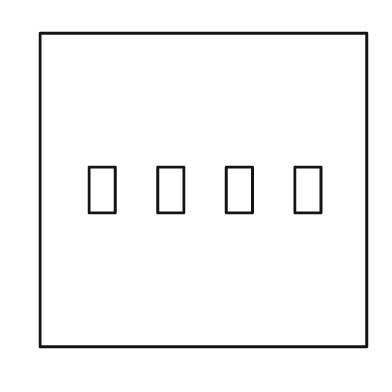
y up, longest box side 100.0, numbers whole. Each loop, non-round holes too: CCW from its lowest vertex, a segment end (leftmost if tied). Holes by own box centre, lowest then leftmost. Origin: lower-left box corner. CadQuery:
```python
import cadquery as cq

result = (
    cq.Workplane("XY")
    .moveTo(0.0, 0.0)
    .lineTo(100.0, 0.0)
    .lineTo(100.0, 96.0)
    .lineTo(0.0, 96.0)
    .close()
    .moveTo(15.0, 41.0)
    .lineTo(23.0, 41.0)
    .lineTo(23.0, 55.0)
    .lineTo(15.0, 55.0)
    .close()
    .moveTo(36.0, 41.0)
    .lineTo(44.0, 41.0)
    .lineTo(44.0, 55.0)
    .lineTo(36.0, 55.0)
    .close()
    .moveTo(57.0, 41.0)
    .lineTo(65.0, 41.0)
    .lineTo(65.0, 55.0)
    .lineTo(57.0, 55.0)
    .close()
    .moveTo(78.0, 41.0)
    .lineTo(86.0, 41.0)
    .lineTo(86.0, 55.0)
    .lineTo(78.0, 55.0)
    .close()
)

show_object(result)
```